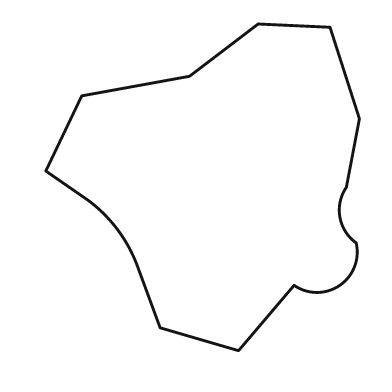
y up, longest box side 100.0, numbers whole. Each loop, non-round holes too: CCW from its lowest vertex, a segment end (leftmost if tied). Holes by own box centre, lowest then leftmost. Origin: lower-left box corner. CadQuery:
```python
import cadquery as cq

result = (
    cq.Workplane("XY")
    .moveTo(59.0, 0.0)
    .lineTo(76.0, 20.0)
    .threePointArc((90.0, 20.0), (95.0, 33.0))
    .threePointArc((90.0, 41.0), (92.0, 50.0))
    .lineTo(96.0, 71.0)
    .lineTo(87.0, 99.0)
    .lineTo(65.0, 100.0)
    .lineTo(44.0, 84.0)
    .lineTo(11.0, 78.0)
    .lineTo(0.0, 55.0)
    .lineTo(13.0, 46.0)
    .threePointArc((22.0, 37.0), (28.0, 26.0))
    .lineTo(35.0, 7.0)
    .close()
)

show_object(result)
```